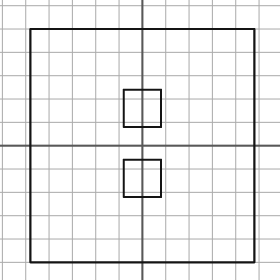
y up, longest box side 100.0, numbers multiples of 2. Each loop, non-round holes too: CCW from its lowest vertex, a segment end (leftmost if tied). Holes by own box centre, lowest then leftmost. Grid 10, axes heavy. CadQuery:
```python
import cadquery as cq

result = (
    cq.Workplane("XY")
    .moveTo(-48.0, -50.0)
    .lineTo(48.0, -50.0)
    .lineTo(48.0, 50.0)
    .lineTo(-48.0, 50.0)
    .close()
    .moveTo(-8.0, -22.0)
    .lineTo(8.0, -22.0)
    .lineTo(8.0, -6.0)
    .lineTo(-8.0, -6.0)
    .close()
    .moveTo(-8.0, 8.0)
    .lineTo(8.0, 8.0)
    .lineTo(8.0, 24.0)
    .lineTo(-8.0, 24.0)
    .close()
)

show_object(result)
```